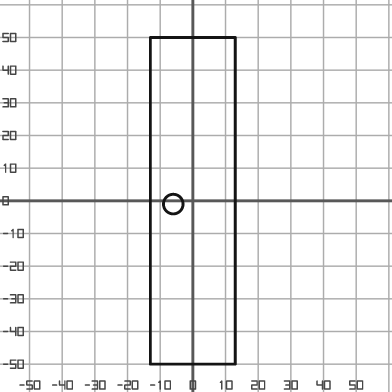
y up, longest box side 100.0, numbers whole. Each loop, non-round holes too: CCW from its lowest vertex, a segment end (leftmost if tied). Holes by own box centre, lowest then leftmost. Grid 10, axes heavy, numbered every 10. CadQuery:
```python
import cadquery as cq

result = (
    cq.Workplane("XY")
    .moveTo(-13.0, -50.0)
    .lineTo(13.0, -50.0)
    .lineTo(13.0, 50.0)
    .lineTo(-13.0, 50.0)
    .close()
    .moveTo(-6.0, -1.0)
    .circle(3.0)
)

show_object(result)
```